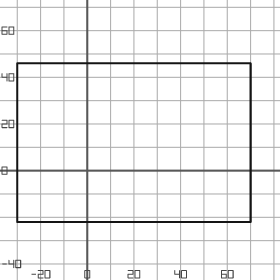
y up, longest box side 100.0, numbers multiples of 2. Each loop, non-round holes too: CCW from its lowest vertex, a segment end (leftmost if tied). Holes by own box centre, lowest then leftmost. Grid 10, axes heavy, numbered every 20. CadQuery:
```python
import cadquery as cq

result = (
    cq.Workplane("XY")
    .moveTo(-30.0, -22.0)
    .lineTo(70.0, -22.0)
    .lineTo(70.0, 46.0)
    .lineTo(-30.0, 46.0)
    .close()
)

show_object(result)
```